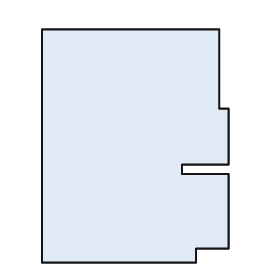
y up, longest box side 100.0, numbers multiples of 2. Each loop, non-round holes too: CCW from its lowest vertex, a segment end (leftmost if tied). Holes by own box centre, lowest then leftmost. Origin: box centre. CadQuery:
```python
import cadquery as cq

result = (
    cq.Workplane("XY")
    .moveTo(-40.0, -50.0)
    .lineTo(26.0, -50.0)
    .lineTo(26.0, -44.0)
    .lineTo(40.0, -44.0)
    .lineTo(40.0, -12.0)
    .lineTo(20.0, -12.0)
    .lineTo(20.0, -8.0)
    .lineTo(40.0, -8.0)
    .lineTo(40.0, 16.0)
    .lineTo(36.0, 16.0)
    .lineTo(36.0, 50.0)
    .lineTo(-40.0, 50.0)
    .close()
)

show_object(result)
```